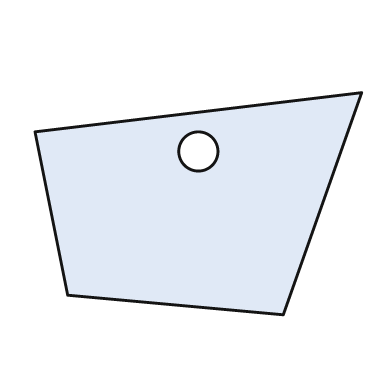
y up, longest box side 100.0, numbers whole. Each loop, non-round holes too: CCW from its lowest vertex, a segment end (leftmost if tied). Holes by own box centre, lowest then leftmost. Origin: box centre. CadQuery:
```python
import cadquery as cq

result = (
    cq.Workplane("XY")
    .moveTo(26.0, -34.0)
    .lineTo(50.0, 34.0)
    .lineTo(-50.0, 22.0)
    .lineTo(-40.0, -28.0)
    .close()
    .moveTo(0.0, 16.0)
    .circle(6.0)
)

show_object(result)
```